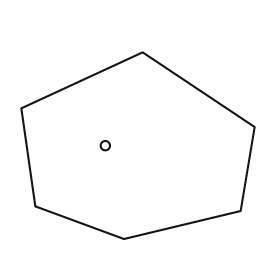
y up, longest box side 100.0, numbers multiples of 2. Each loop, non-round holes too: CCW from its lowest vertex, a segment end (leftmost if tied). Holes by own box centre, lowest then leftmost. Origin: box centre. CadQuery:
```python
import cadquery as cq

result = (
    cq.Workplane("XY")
    .moveTo(-6.0, -40.0)
    .lineTo(44.0, -28.0)
    .lineTo(50.0, 8.0)
    .lineTo(2.0, 40.0)
    .lineTo(-50.0, 16.0)
    .lineTo(-44.0, -26.0)
    .close()
    .moveTo(-14.0, 0.0)
    .circle(2.0)
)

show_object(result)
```